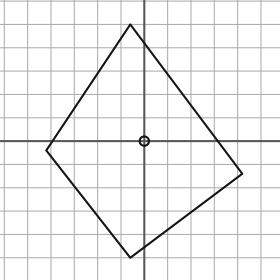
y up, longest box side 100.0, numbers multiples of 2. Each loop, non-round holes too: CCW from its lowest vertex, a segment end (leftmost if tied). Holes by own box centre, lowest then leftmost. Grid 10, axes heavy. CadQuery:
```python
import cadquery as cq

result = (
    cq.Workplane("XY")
    .moveTo(-6.0, -50.0)
    .lineTo(42.0, -14.0)
    .lineTo(-6.0, 50.0)
    .lineTo(-42.0, -4.0)
    .close()
    .moveTo(0.0, 0.0)
    .circle(2.0)
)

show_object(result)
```